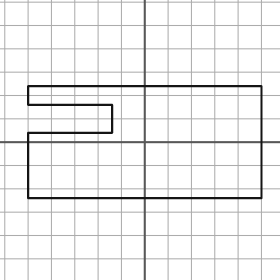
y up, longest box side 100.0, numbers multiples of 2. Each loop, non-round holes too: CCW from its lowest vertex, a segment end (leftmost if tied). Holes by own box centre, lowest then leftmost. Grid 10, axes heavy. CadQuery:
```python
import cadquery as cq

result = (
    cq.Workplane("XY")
    .moveTo(-50.0, -24.0)
    .lineTo(50.0, -24.0)
    .lineTo(50.0, 24.0)
    .lineTo(-50.0, 24.0)
    .lineTo(-50.0, 16.0)
    .lineTo(-14.0, 16.0)
    .lineTo(-14.0, 4.0)
    .lineTo(-50.0, 4.0)
    .close()
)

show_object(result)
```